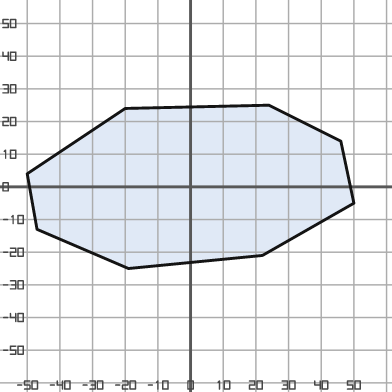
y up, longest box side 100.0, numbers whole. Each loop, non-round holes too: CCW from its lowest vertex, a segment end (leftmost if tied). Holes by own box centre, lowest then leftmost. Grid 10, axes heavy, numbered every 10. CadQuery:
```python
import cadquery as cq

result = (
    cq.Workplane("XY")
    .moveTo(-19.0, -25.0)
    .lineTo(22.0, -21.0)
    .lineTo(50.0, -5.0)
    .lineTo(46.0, 14.0)
    .lineTo(24.0, 25.0)
    .lineTo(-20.0, 24.0)
    .lineTo(-50.0, 4.0)
    .lineTo(-47.0, -13.0)
    .close()
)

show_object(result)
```